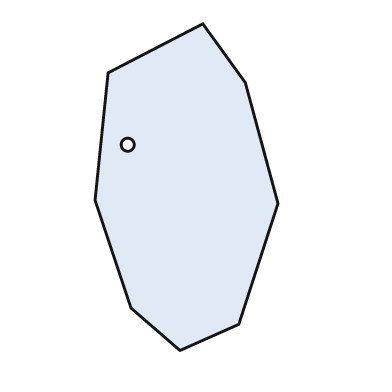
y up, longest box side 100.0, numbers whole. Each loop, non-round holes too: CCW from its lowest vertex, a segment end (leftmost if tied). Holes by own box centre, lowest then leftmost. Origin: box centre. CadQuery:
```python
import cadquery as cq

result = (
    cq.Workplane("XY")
    .moveTo(-2.0, -50.0)
    .lineTo(16.0, -42.0)
    .lineTo(28.0, -5.0)
    .lineTo(18.0, 32.0)
    .lineTo(5.0, 50.0)
    .lineTo(-24.0, 35.0)
    .lineTo(-28.0, -4.0)
    .lineTo(-17.0, -37.0)
    .close()
    .moveTo(-18.0, 13.0)
    .circle(2.0)
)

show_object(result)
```